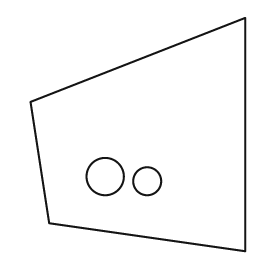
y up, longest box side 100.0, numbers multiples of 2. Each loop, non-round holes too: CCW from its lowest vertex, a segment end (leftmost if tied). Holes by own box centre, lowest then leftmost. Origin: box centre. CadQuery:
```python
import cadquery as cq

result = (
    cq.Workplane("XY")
    .moveTo(46.0, -50.0)
    .lineTo(46.0, 50.0)
    .lineTo(-46.0, 14.0)
    .lineTo(-38.0, -38.0)
    .close()
    .moveTo(4.0, -20.0)
    .circle(6.0)
    .moveTo(-14.0, -18.0)
    .circle(8.0)
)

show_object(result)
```